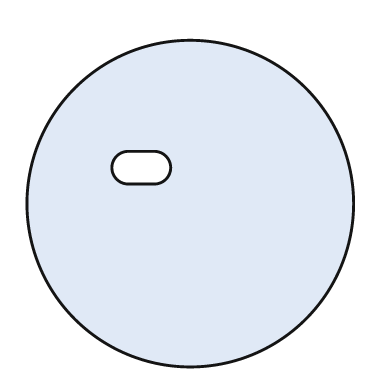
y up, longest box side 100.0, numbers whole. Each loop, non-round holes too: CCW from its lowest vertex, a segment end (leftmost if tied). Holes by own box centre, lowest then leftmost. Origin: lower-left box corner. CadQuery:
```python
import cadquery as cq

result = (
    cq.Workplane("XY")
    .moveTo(50.0, 50.0)
    .circle(50.0)
    .moveTo(31.0, 56.0)
    .lineTo(39.0, 56.0)
    .threePointArc((44.0, 61.0), (39.0, 66.0))
    .lineTo(31.0, 66.0)
    .threePointArc((26.0, 61.0), (31.0, 56.0))
    .close()
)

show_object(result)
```